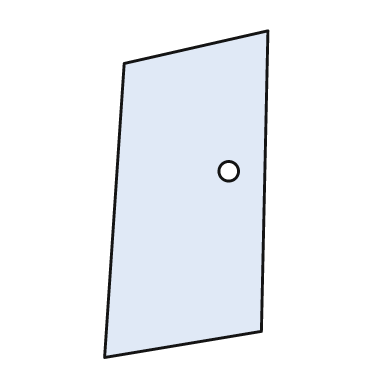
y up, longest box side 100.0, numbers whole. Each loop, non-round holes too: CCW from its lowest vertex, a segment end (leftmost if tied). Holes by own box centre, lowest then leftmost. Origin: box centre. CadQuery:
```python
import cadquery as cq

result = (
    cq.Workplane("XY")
    .moveTo(-25.0, -50.0)
    .lineTo(23.0, -42.0)
    .lineTo(25.0, 50.0)
    .lineTo(-19.0, 40.0)
    .close()
    .moveTo(13.0, 7.0)
    .circle(3.0)
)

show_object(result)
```